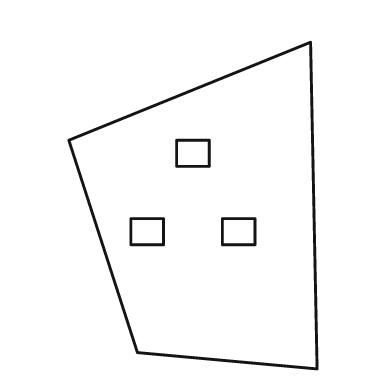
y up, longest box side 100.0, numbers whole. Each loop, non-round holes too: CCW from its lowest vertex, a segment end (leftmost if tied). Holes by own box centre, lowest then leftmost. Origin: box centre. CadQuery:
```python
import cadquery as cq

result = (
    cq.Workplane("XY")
    .moveTo(38.0, -50.0)
    .lineTo(36.0, 50.0)
    .lineTo(-38.0, 20.0)
    .lineTo(-17.0, -45.0)
    .close()
    .moveTo(-19.0, -12.0)
    .lineTo(-9.0, -12.0)
    .lineTo(-9.0, -4.0)
    .lineTo(-19.0, -4.0)
    .close()
    .moveTo(9.0, -12.0)
    .lineTo(19.0, -12.0)
    .lineTo(19.0, -4.0)
    .lineTo(9.0, -4.0)
    .close()
    .moveTo(-5.0, 12.0)
    .lineTo(5.0, 12.0)
    .lineTo(5.0, 20.0)
    .lineTo(-5.0, 20.0)
    .close()
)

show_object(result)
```